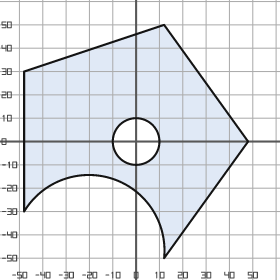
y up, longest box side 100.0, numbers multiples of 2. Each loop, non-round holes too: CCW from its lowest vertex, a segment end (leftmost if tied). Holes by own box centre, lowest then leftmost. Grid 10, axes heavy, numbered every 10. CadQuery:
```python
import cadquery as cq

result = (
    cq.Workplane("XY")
    .moveTo(12.0, -50.0)
    .lineTo(48.0, 0.0)
    .lineTo(12.0, 50.0)
    .lineTo(-48.0, 30.0)
    .lineTo(-48.0, -30.0)
    .threePointArc((-10.0, -16.0), (12.0, -50.0))
    .close()
    .moveTo(0.0, 0.0)
    .circle(10.0)
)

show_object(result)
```